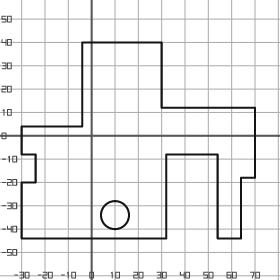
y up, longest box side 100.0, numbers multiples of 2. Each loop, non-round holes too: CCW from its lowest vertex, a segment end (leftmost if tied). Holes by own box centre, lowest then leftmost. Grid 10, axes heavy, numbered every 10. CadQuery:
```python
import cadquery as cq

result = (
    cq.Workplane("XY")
    .moveTo(-30.0, -44.0)
    .lineTo(32.0, -44.0)
    .lineTo(32.0, -8.0)
    .lineTo(54.0, -8.0)
    .lineTo(54.0, -44.0)
    .lineTo(64.0, -44.0)
    .lineTo(64.0, -18.0)
    .lineTo(70.0, -18.0)
    .lineTo(70.0, 12.0)
    .lineTo(30.0, 12.0)
    .lineTo(30.0, 40.0)
    .lineTo(-4.0, 40.0)
    .lineTo(-4.0, 4.0)
    .lineTo(-30.0, 4.0)
    .lineTo(-30.0, -8.0)
    .lineTo(-24.0, -8.0)
    .lineTo(-24.0, -20.0)
    .lineTo(-30.0, -20.0)
    .close()
    .moveTo(10.0, -34.0)
    .circle(6.0)
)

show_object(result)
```